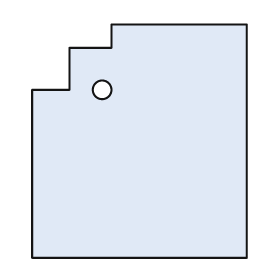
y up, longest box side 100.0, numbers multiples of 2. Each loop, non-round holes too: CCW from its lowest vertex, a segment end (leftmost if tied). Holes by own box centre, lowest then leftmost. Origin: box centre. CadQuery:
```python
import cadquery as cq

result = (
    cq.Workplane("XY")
    .moveTo(-46.0, -50.0)
    .lineTo(46.0, -50.0)
    .lineTo(46.0, 50.0)
    .lineTo(-12.0, 50.0)
    .lineTo(-12.0, 40.0)
    .lineTo(-30.0, 40.0)
    .lineTo(-30.0, 22.0)
    .lineTo(-46.0, 22.0)
    .close()
    .moveTo(-16.0, 22.0)
    .circle(4.0)
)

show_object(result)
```